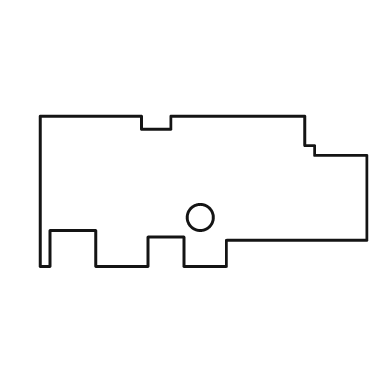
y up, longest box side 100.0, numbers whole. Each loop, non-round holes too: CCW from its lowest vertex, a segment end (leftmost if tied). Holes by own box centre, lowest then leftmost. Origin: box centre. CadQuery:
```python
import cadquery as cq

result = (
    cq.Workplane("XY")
    .moveTo(-50.0, -23.0)
    .lineTo(-47.0, -23.0)
    .lineTo(-47.0, -12.0)
    .lineTo(-33.0, -12.0)
    .lineTo(-33.0, -23.0)
    .lineTo(-17.0, -23.0)
    .lineTo(-17.0, -14.0)
    .lineTo(-6.0, -14.0)
    .lineTo(-6.0, -23.0)
    .lineTo(7.0, -23.0)
    .lineTo(7.0, -15.0)
    .lineTo(50.0, -15.0)
    .lineTo(50.0, 11.0)
    .lineTo(34.0, 11.0)
    .lineTo(34.0, 14.0)
    .lineTo(31.0, 14.0)
    .lineTo(31.0, 23.0)
    .lineTo(-10.0, 23.0)
    .lineTo(-10.0, 19.0)
    .lineTo(-19.0, 19.0)
    .lineTo(-19.0, 23.0)
    .lineTo(-50.0, 23.0)
    .close()
    .moveTo(-1.0, -8.0)
    .circle(4.0)
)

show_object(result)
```